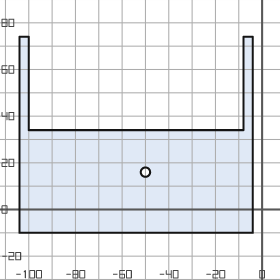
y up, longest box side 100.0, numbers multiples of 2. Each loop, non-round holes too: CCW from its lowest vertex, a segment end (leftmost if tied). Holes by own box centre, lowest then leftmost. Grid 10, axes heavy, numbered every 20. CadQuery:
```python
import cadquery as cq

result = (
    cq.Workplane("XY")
    .moveTo(-104.0, -10.0)
    .lineTo(-4.0, -10.0)
    .lineTo(-4.0, 74.0)
    .lineTo(-8.0, 74.0)
    .lineTo(-8.0, 34.0)
    .lineTo(-100.0, 34.0)
    .lineTo(-100.0, 74.0)
    .lineTo(-104.0, 74.0)
    .close()
    .moveTo(-50.0, 16.0)
    .circle(2.0)
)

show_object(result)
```